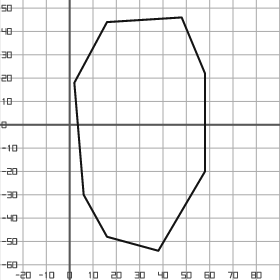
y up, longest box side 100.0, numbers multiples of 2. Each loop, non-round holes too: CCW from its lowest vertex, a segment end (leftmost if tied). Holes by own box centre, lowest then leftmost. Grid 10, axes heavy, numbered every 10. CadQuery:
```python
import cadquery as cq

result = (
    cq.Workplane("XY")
    .moveTo(38.0, -54.0)
    .lineTo(58.0, -20.0)
    .lineTo(58.0, 22.0)
    .lineTo(48.0, 46.0)
    .lineTo(16.0, 44.0)
    .lineTo(2.0, 18.0)
    .lineTo(6.0, -30.0)
    .lineTo(16.0, -48.0)
    .close()
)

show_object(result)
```